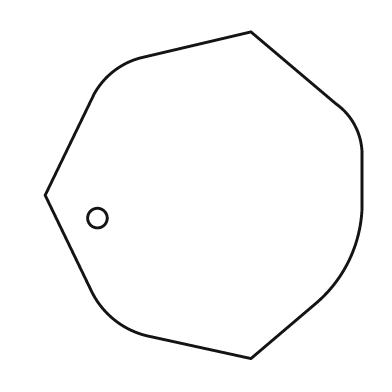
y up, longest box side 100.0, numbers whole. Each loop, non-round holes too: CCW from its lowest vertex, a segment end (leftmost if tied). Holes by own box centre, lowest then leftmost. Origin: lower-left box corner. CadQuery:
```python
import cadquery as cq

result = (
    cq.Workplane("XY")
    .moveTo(63.0, 0.0)
    .lineTo(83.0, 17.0)
    .threePointArc((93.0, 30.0), (97.0, 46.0))
    .lineTo(97.0, 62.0)
    .threePointArc((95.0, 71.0), (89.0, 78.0))
    .lineTo(63.0, 100.0)
    .lineTo(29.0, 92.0)
    .threePointArc((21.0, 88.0), (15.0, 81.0))
    .lineTo(0.0, 50.0)
    .lineTo(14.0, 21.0)
    .threePointArc((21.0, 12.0), (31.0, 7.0))
    .close()
    .moveTo(16.0, 43.0)
    .circle(3.0)
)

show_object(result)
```